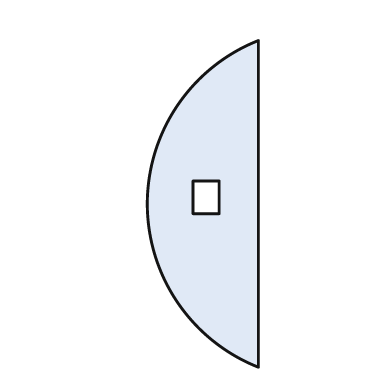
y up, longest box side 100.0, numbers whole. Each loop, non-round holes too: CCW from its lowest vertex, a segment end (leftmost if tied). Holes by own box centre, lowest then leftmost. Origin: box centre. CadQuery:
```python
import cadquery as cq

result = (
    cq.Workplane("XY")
    .moveTo(17.0, -50.0)
    .lineTo(17.0, 50.0)
    .threePointArc((-17.0, 0.0), (17.0, -50.0))
    .close()
    .moveTo(-3.0, -3.0)
    .lineTo(5.0, -3.0)
    .lineTo(5.0, 7.0)
    .lineTo(-3.0, 7.0)
    .close()
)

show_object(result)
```